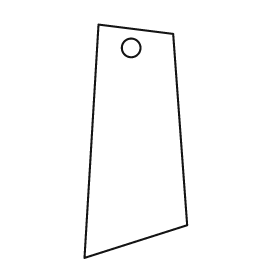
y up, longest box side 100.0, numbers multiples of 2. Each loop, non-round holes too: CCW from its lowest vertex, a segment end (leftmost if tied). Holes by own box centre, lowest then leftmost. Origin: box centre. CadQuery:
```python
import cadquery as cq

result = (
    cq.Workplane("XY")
    .moveTo(-22.0, -50.0)
    .lineTo(22.0, -36.0)
    .lineTo(16.0, 46.0)
    .lineTo(-16.0, 50.0)
    .close()
    .moveTo(-2.0, 40.0)
    .circle(4.0)
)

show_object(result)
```